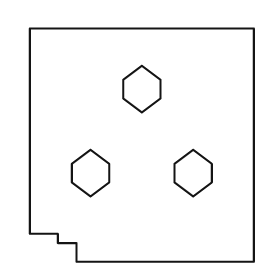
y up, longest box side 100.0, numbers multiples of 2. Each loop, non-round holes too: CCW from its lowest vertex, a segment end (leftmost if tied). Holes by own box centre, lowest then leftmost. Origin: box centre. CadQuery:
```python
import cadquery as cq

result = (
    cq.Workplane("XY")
    .moveTo(-28.0, -50.0)
    .lineTo(48.0, -50.0)
    .lineTo(48.0, 50.0)
    .lineTo(-48.0, 50.0)
    .lineTo(-48.0, -38.0)
    .lineTo(-36.0, -38.0)
    .lineTo(-36.0, -42.0)
    .lineTo(-28.0, -42.0)
    .close()
    .moveTo(-22.0, -22.0)
    .lineTo(-14.0, -16.0)
    .lineTo(-14.0, -8.0)
    .lineTo(-22.0, -2.0)
    .lineTo(-30.0, -8.0)
    .lineTo(-30.0, -16.0)
    .close()
    .moveTo(22.0, -22.0)
    .lineTo(30.0, -16.0)
    .lineTo(30.0, -8.0)
    .lineTo(22.0, -2.0)
    .lineTo(14.0, -8.0)
    .lineTo(14.0, -16.0)
    .close()
    .moveTo(0.0, 14.0)
    .lineTo(8.0, 20.0)
    .lineTo(8.0, 28.0)
    .lineTo(0.0, 34.0)
    .lineTo(-8.0, 28.0)
    .lineTo(-8.0, 20.0)
    .close()
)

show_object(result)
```